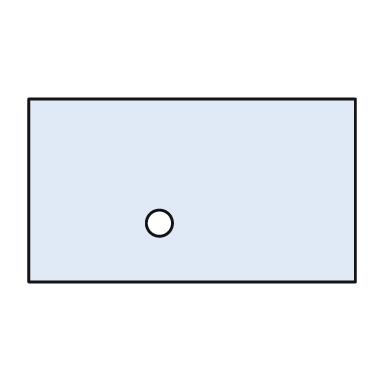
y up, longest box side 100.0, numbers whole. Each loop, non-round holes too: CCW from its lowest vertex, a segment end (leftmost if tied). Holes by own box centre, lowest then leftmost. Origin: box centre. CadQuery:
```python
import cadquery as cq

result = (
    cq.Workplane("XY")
    .moveTo(-50.0, -28.0)
    .lineTo(50.0, -28.0)
    .lineTo(50.0, 28.0)
    .lineTo(-50.0, 28.0)
    .close()
    .moveTo(-10.0, -10.0)
    .circle(4.0)
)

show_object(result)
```